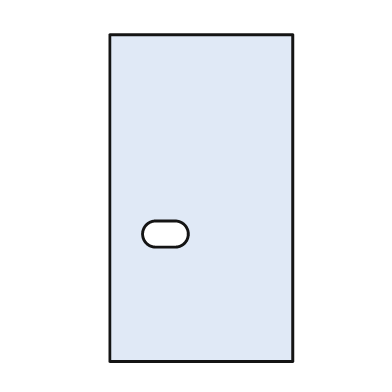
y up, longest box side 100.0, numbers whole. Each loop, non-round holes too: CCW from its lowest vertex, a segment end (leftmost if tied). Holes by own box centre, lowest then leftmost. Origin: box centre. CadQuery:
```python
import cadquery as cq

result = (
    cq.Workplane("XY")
    .moveTo(-28.0, -50.0)
    .lineTo(28.0, -50.0)
    .lineTo(28.0, 50.0)
    .lineTo(-28.0, 50.0)
    .close()
    .moveTo(-14.0, -15.0)
    .lineTo(-8.0, -15.0)
    .threePointArc((-4.0, -11.0), (-8.0, -7.0))
    .lineTo(-14.0, -7.0)
    .threePointArc((-18.0, -11.0), (-14.0, -15.0))
    .close()
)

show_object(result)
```